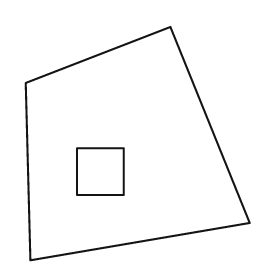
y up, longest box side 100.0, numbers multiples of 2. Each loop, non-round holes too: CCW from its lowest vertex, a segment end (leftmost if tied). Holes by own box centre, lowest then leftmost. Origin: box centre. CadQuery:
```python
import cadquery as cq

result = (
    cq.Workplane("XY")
    .moveTo(-46.0, -50.0)
    .lineTo(48.0, -34.0)
    .lineTo(14.0, 50.0)
    .lineTo(-48.0, 26.0)
    .close()
    .moveTo(-26.0, -22.0)
    .lineTo(-6.0, -22.0)
    .lineTo(-6.0, -2.0)
    .lineTo(-26.0, -2.0)
    .close()
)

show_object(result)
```